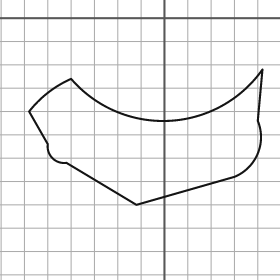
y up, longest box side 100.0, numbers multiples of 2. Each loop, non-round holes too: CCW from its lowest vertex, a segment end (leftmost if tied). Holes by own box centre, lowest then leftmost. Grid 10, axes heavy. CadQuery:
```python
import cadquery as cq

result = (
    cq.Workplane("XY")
    .moveTo(-12.0, -80.0)
    .lineTo(30.0, -68.0)
    .threePointArc((40.0, -58.0), (40.0, -44.0))
    .lineTo(42.0, -22.0)
    .threePointArc((2.0, -44.0), (-40.0, -26.0))
    .threePointArc((-50.0, -32.0), (-58.0, -40.0))
    .lineTo(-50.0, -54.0)
    .threePointArc((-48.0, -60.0), (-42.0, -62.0))
    .close()
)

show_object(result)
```